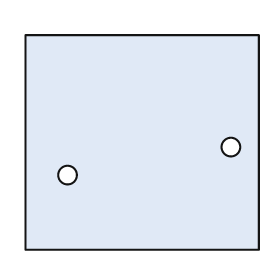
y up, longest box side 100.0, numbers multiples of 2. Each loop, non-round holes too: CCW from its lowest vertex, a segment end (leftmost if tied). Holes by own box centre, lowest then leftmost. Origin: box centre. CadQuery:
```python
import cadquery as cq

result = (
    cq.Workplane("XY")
    .moveTo(-50.0, -46.0)
    .lineTo(50.0, -46.0)
    .lineTo(50.0, 46.0)
    .lineTo(-50.0, 46.0)
    .close()
    .moveTo(-32.0, -14.0)
    .circle(4.0)
    .moveTo(38.0, -2.0)
    .circle(4.0)
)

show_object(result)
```